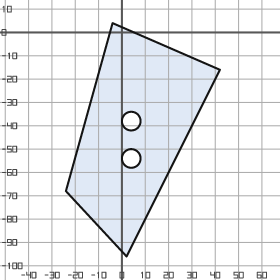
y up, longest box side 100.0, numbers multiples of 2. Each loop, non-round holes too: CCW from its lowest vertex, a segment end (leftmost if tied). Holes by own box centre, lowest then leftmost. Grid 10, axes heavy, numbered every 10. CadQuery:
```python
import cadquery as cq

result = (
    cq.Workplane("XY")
    .moveTo(2.0, -96.0)
    .lineTo(42.0, -16.0)
    .lineTo(-4.0, 4.0)
    .lineTo(-24.0, -68.0)
    .close()
    .moveTo(4.0, -54.0)
    .circle(4.0)
    .moveTo(4.0, -38.0)
    .circle(4.0)
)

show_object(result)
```